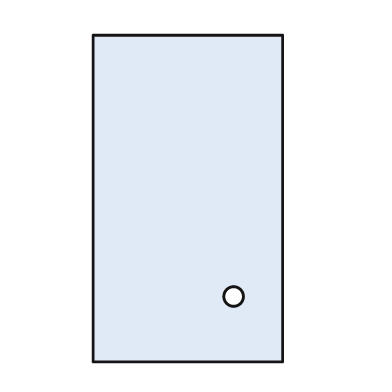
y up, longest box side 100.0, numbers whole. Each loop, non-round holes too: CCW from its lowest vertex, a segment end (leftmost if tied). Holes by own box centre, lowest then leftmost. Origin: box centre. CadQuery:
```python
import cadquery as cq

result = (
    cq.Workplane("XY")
    .moveTo(-29.0, -50.0)
    .lineTo(29.0, -50.0)
    .lineTo(29.0, 50.0)
    .lineTo(-29.0, 50.0)
    .close()
    .moveTo(14.0, -30.0)
    .circle(3.0)
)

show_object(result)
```